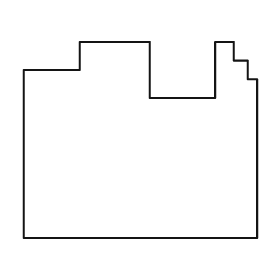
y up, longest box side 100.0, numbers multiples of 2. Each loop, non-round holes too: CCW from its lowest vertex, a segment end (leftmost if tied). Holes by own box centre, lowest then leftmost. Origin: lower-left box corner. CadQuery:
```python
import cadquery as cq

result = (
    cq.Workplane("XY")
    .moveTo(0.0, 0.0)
    .lineTo(100.0, 0.0)
    .lineTo(100.0, 68.0)
    .lineTo(96.0, 68.0)
    .lineTo(96.0, 76.0)
    .lineTo(90.0, 76.0)
    .lineTo(90.0, 84.0)
    .lineTo(82.0, 84.0)
    .lineTo(82.0, 60.0)
    .lineTo(54.0, 60.0)
    .lineTo(54.0, 84.0)
    .lineTo(24.0, 84.0)
    .lineTo(24.0, 72.0)
    .lineTo(0.0, 72.0)
    .close()
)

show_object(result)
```